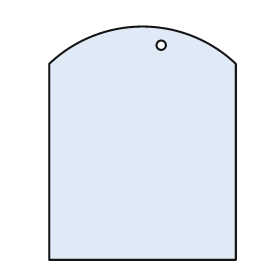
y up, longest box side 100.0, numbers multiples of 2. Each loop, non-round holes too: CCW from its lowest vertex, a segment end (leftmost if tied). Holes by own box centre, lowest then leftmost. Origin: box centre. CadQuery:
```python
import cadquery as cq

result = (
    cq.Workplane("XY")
    .moveTo(-40.0, -50.0)
    .lineTo(40.0, -50.0)
    .lineTo(40.0, 34.0)
    .threePointArc((0.0, 50.0), (-40.0, 34.0))
    .close()
    .moveTo(8.0, 42.0)
    .circle(2.0)
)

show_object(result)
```